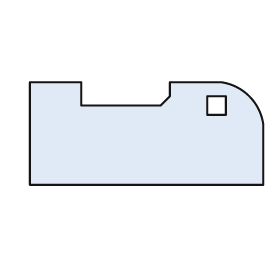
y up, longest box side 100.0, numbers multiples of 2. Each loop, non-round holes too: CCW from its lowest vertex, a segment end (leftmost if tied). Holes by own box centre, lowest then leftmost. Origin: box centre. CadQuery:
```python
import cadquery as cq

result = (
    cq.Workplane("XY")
    .moveTo(-50.0, -22.0)
    .lineTo(50.0, -22.0)
    .lineTo(50.0, 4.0)
    .threePointArc((44.0, 16.0), (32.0, 22.0))
    .lineTo(10.0, 22.0)
    .lineTo(10.0, 16.0)
    .lineTo(6.0, 12.0)
    .lineTo(-28.0, 12.0)
    .lineTo(-28.0, 22.0)
    .lineTo(-50.0, 22.0)
    .close()
    .moveTo(26.0, 8.0)
    .lineTo(34.0, 8.0)
    .lineTo(34.0, 16.0)
    .lineTo(26.0, 16.0)
    .close()
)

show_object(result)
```